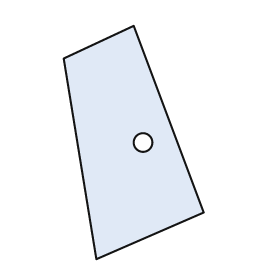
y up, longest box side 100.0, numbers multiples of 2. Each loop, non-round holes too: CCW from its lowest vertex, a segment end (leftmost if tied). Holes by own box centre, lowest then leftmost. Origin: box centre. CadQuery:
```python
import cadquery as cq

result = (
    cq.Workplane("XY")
    .moveTo(-16.0, -50.0)
    .lineTo(30.0, -30.0)
    .lineTo(0.0, 50.0)
    .lineTo(-30.0, 36.0)
    .close()
    .moveTo(4.0, 0.0)
    .circle(4.0)
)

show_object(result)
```